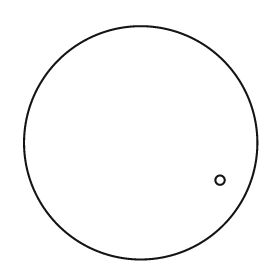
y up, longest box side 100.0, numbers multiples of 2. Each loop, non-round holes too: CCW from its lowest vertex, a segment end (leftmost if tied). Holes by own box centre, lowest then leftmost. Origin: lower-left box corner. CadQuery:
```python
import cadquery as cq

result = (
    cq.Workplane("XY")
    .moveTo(50.0, 50.0)
    .circle(50.0)
    .moveTo(84.0, 34.0)
    .circle(2.0)
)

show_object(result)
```